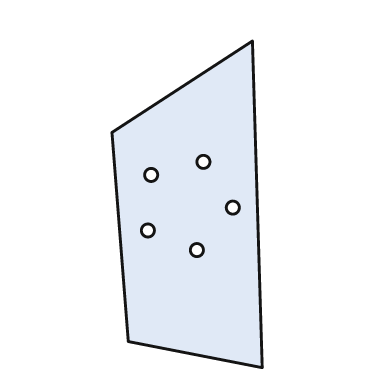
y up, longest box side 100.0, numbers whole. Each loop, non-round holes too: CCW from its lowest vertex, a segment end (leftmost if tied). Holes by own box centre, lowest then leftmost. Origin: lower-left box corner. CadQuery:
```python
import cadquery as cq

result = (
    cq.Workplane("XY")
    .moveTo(46.0, 0.0)
    .lineTo(43.0, 100.0)
    .lineTo(0.0, 72.0)
    .lineTo(5.0, 8.0)
    .close()
    .moveTo(26.0, 36.0)
    .circle(2.0)
    .moveTo(11.0, 42.0)
    .circle(2.0)
    .moveTo(37.0, 49.0)
    .circle(2.0)
    .moveTo(12.0, 59.0)
    .circle(2.0)
    .moveTo(28.0, 63.0)
    .circle(2.0)
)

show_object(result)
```